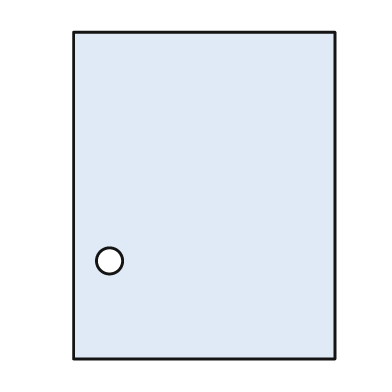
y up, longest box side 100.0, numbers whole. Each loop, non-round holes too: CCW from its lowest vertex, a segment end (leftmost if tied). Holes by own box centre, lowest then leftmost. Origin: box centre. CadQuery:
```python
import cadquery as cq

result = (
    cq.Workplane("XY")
    .moveTo(-40.0, -50.0)
    .lineTo(40.0, -50.0)
    .lineTo(40.0, 50.0)
    .lineTo(-40.0, 50.0)
    .close()
    .moveTo(-29.0, -20.0)
    .circle(4.0)
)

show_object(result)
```